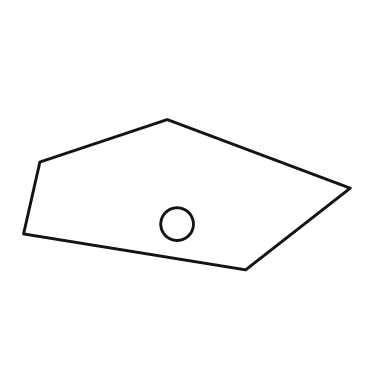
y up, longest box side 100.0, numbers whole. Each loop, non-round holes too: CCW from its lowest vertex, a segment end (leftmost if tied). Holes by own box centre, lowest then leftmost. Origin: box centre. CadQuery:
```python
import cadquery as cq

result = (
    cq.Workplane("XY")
    .moveTo(18.0, -23.0)
    .lineTo(50.0, 2.0)
    .lineTo(-6.0, 23.0)
    .lineTo(-45.0, 10.0)
    .lineTo(-50.0, -12.0)
    .close()
    .moveTo(-3.0, -9.0)
    .circle(5.0)
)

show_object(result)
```